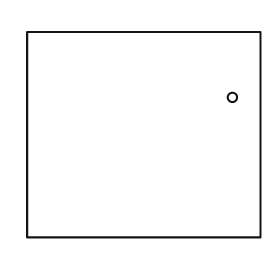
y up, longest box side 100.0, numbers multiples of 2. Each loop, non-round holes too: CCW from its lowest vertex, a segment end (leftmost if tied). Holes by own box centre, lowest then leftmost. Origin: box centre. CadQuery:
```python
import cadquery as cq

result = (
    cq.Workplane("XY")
    .moveTo(-50.0, -44.0)
    .lineTo(50.0, -44.0)
    .lineTo(50.0, 44.0)
    .lineTo(-50.0, 44.0)
    .close()
    .moveTo(38.0, 16.0)
    .circle(2.0)
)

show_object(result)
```